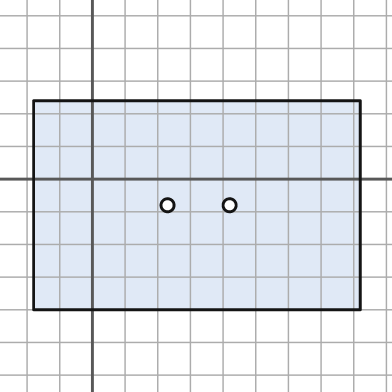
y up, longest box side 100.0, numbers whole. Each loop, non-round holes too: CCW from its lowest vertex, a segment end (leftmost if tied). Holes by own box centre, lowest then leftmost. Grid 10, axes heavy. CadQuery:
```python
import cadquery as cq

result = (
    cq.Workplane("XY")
    .moveTo(-18.0, -40.0)
    .lineTo(82.0, -40.0)
    .lineTo(82.0, 24.0)
    .lineTo(-18.0, 24.0)
    .close()
    .moveTo(23.0, -8.0)
    .circle(2.0)
    .moveTo(42.0, -8.0)
    .circle(2.0)
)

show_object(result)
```